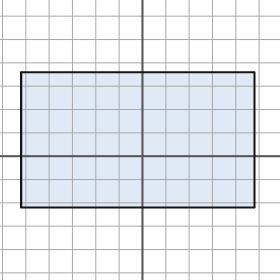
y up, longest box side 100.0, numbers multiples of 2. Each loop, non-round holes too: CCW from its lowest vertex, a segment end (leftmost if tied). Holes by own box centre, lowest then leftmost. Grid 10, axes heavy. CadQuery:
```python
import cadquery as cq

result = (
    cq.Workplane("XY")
    .moveTo(-52.0, -22.0)
    .lineTo(48.0, -22.0)
    .lineTo(48.0, 36.0)
    .lineTo(-52.0, 36.0)
    .close()
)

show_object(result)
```